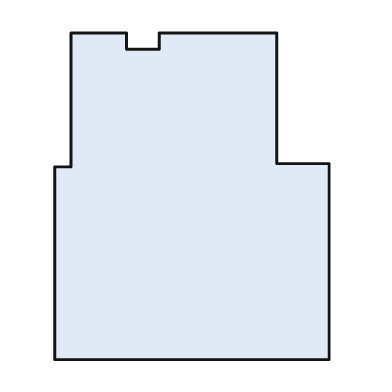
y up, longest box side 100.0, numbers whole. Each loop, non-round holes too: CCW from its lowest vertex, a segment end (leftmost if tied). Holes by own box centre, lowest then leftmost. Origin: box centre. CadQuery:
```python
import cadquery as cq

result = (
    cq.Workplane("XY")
    .moveTo(-42.0, -50.0)
    .lineTo(42.0, -50.0)
    .lineTo(42.0, 10.0)
    .lineTo(26.0, 10.0)
    .lineTo(26.0, 50.0)
    .lineTo(-10.0, 50.0)
    .lineTo(-10.0, 45.0)
    .lineTo(-20.0, 45.0)
    .lineTo(-20.0, 50.0)
    .lineTo(-37.0, 50.0)
    .lineTo(-37.0, 9.0)
    .lineTo(-42.0, 9.0)
    .close()
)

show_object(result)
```